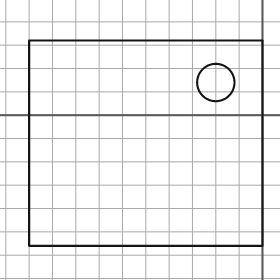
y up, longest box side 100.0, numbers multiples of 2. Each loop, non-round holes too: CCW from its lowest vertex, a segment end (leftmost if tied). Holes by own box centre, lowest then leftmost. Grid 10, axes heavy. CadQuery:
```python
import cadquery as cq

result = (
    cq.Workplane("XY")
    .moveTo(-100.0, -56.0)
    .lineTo(0.0, -56.0)
    .lineTo(0.0, 32.0)
    .lineTo(-100.0, 32.0)
    .close()
    .moveTo(-20.0, 14.0)
    .circle(8.0)
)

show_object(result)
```